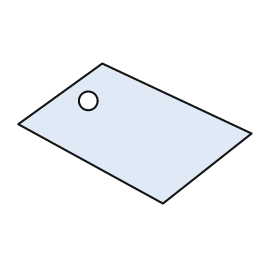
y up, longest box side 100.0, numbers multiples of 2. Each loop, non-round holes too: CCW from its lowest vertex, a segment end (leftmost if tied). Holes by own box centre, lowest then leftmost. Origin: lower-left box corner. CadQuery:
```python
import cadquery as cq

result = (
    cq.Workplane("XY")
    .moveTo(62.0, 0.0)
    .lineTo(100.0, 30.0)
    .lineTo(36.0, 60.0)
    .lineTo(0.0, 34.0)
    .close()
    .moveTo(30.0, 44.0)
    .circle(4.0)
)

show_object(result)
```